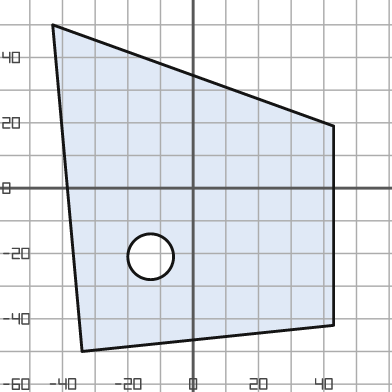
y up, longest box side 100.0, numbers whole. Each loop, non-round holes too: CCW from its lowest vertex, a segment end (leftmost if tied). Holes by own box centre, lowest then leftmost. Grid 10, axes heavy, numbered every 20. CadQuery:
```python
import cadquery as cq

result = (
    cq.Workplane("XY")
    .moveTo(-34.0, -50.0)
    .lineTo(43.0, -42.0)
    .lineTo(43.0, 19.0)
    .lineTo(-43.0, 50.0)
    .close()
    .moveTo(-13.0, -21.0)
    .circle(7.0)
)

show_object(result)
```